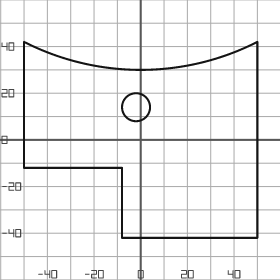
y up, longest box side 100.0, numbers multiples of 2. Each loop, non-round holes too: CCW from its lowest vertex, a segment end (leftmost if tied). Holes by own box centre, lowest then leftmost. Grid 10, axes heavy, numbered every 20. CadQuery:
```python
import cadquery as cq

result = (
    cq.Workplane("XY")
    .moveTo(-8.0, -42.0)
    .lineTo(50.0, -42.0)
    .lineTo(50.0, 42.0)
    .threePointArc((0.0, 30.0), (-50.0, 42.0))
    .lineTo(-50.0, -12.0)
    .lineTo(-8.0, -12.0)
    .close()
    .moveTo(-2.0, 14.0)
    .circle(6.0)
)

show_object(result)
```